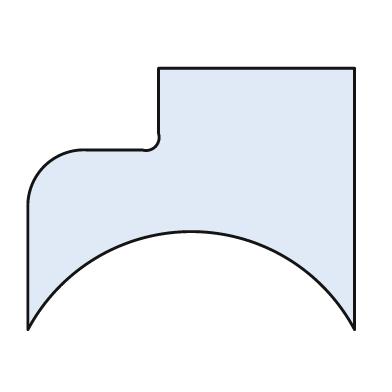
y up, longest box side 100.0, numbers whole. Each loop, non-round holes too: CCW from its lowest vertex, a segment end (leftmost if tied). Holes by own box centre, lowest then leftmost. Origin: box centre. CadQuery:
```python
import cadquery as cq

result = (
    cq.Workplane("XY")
    .moveTo(-50.0, -40.0)
    .threePointArc((0.0, -10.0), (50.0, -40.0))
    .lineTo(50.0, 40.0)
    .lineTo(-10.0, 40.0)
    .lineTo(-10.0, 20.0)
    .threePointArc((-11.0, 16.0), (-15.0, 15.0))
    .lineTo(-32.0, 15.0)
    .threePointArc((-45.0, 10.0), (-50.0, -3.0))
    .close()
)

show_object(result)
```